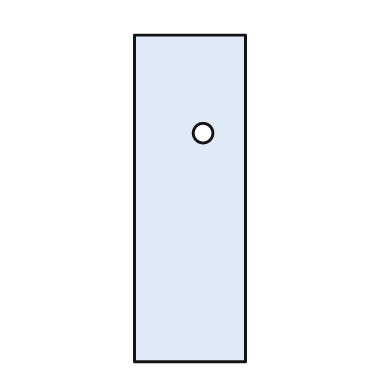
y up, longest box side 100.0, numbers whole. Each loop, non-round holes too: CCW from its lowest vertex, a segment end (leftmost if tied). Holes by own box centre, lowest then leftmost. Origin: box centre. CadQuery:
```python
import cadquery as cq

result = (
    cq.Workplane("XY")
    .moveTo(-17.0, -50.0)
    .lineTo(17.0, -50.0)
    .lineTo(17.0, 50.0)
    .lineTo(-17.0, 50.0)
    .close()
    .moveTo(4.0, 20.0)
    .circle(3.0)
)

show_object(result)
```